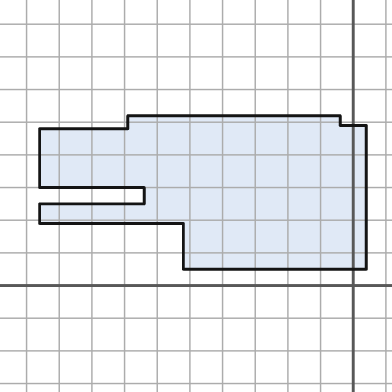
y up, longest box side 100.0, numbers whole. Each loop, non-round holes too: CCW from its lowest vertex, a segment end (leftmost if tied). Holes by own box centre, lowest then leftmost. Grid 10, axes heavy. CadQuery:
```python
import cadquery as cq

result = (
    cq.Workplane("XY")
    .moveTo(-52.0, 5.0)
    .lineTo(4.0, 5.0)
    .lineTo(4.0, 49.0)
    .lineTo(-4.0, 49.0)
    .lineTo(-4.0, 52.0)
    .lineTo(-69.0, 52.0)
    .lineTo(-69.0, 48.0)
    .lineTo(-96.0, 48.0)
    .lineTo(-96.0, 30.0)
    .lineTo(-64.0, 30.0)
    .lineTo(-64.0, 25.0)
    .lineTo(-96.0, 25.0)
    .lineTo(-96.0, 19.0)
    .lineTo(-52.0, 19.0)
    .close()
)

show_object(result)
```